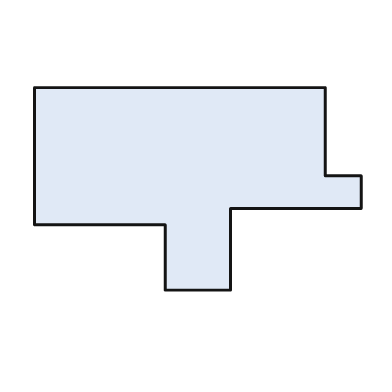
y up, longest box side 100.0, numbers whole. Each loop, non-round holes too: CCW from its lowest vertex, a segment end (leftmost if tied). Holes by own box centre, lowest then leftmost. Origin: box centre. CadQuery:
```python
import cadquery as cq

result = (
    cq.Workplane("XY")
    .moveTo(-10.0, -31.0)
    .lineTo(10.0, -31.0)
    .lineTo(10.0, -6.0)
    .lineTo(50.0, -6.0)
    .lineTo(50.0, 4.0)
    .lineTo(39.0, 4.0)
    .lineTo(39.0, 31.0)
    .lineTo(-50.0, 31.0)
    .lineTo(-50.0, -11.0)
    .lineTo(-10.0, -11.0)
    .close()
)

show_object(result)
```